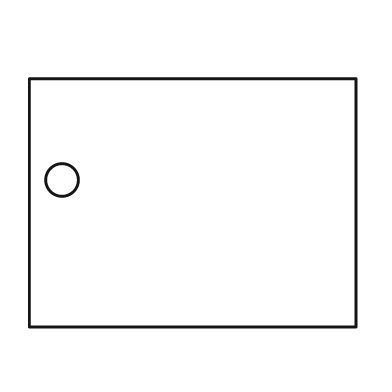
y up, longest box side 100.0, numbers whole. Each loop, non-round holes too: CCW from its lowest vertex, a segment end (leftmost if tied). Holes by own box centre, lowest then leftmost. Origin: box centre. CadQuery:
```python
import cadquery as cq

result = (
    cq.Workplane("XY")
    .moveTo(-50.0, -38.0)
    .lineTo(50.0, -38.0)
    .lineTo(50.0, 38.0)
    .lineTo(-50.0, 38.0)
    .close()
    .moveTo(-40.0, 7.0)
    .circle(5.0)
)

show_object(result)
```